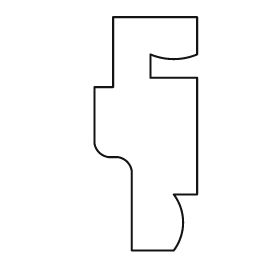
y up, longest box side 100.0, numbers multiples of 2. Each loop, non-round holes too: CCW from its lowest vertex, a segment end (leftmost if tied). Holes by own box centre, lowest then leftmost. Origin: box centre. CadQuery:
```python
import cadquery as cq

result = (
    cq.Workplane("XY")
    .moveTo(-6.0, -50.0)
    .lineTo(12.0, -50.0)
    .threePointArc((16.0, -38.0), (12.0, -26.0))
    .lineTo(22.0, -26.0)
    .lineTo(22.0, 24.0)
    .lineTo(2.0, 24.0)
    .lineTo(2.0, 34.0)
    .threePointArc((12.0, 32.0), (22.0, 34.0))
    .lineTo(22.0, 50.0)
    .lineTo(-14.0, 50.0)
    .lineTo(-14.0, 20.0)
    .lineTo(-22.0, 20.0)
    .lineTo(-22.0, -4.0)
    .threePointArc((-20.0, -8.0), (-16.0, -10.0))
    .lineTo(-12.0, -10.0)
    .threePointArc((-8.0, -12.0), (-6.0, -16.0))
    .close()
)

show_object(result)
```